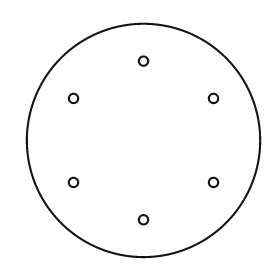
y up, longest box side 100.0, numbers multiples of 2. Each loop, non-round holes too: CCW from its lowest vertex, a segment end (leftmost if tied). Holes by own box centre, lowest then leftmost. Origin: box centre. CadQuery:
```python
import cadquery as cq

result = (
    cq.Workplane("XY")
    .moveTo(0.0, 0.0)
    .circle(50.0)
    .moveTo(0.0, -34.0)
    .circle(2.0)
    .moveTo(-30.0, -18.0)
    .circle(2.0)
    .moveTo(30.0, -18.0)
    .circle(2.0)
    .moveTo(-30.0, 18.0)
    .circle(2.0)
    .moveTo(30.0, 18.0)
    .circle(2.0)
    .moveTo(0.0, 34.0)
    .circle(2.0)
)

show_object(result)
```